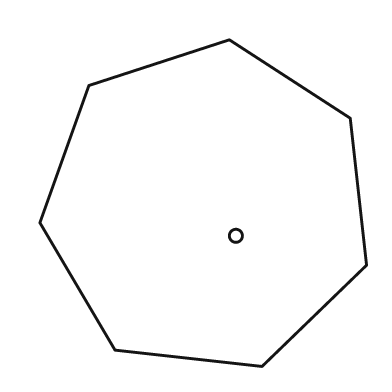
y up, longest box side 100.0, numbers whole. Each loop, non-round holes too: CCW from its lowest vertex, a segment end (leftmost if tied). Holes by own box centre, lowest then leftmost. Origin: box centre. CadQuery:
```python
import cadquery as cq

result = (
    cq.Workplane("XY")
    .moveTo(18.0, -50.0)
    .lineTo(50.0, -19.0)
    .lineTo(45.0, 26.0)
    .lineTo(8.0, 50.0)
    .lineTo(-35.0, 36.0)
    .lineTo(-50.0, -6.0)
    .lineTo(-27.0, -45.0)
    .close()
    .moveTo(10.0, -10.0)
    .circle(2.0)
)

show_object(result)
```